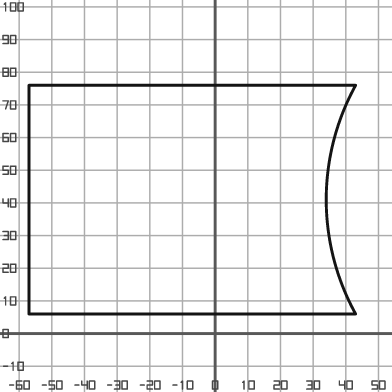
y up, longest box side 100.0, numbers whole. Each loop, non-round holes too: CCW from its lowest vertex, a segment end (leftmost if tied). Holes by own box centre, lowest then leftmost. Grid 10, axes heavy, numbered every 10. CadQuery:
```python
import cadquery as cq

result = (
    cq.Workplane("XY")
    .moveTo(-57.0, 6.0)
    .lineTo(43.0, 6.0)
    .threePointArc((34.0, 41.0), (43.0, 76.0))
    .lineTo(-57.0, 76.0)
    .close()
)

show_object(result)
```